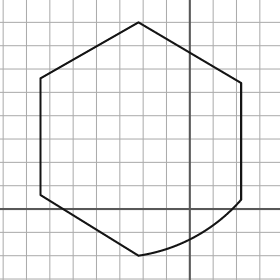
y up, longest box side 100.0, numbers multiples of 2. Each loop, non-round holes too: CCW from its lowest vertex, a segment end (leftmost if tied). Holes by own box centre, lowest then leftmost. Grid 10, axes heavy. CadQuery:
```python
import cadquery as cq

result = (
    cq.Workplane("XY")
    .moveTo(-22.0, -20.0)
    .threePointArc((2.0, -12.0), (22.0, 4.0))
    .lineTo(22.0, 54.0)
    .lineTo(-22.0, 80.0)
    .lineTo(-64.0, 56.0)
    .lineTo(-64.0, 6.0)
    .close()
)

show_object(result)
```